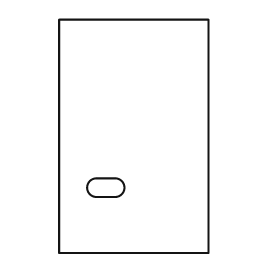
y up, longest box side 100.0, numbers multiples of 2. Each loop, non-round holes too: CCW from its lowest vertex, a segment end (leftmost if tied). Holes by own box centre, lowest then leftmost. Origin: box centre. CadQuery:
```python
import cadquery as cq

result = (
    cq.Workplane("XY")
    .moveTo(-32.0, -50.0)
    .lineTo(32.0, -50.0)
    .lineTo(32.0, 50.0)
    .lineTo(-32.0, 50.0)
    .close()
    .moveTo(-16.0, -26.0)
    .lineTo(-8.0, -26.0)
    .threePointArc((-4.0, -22.0), (-8.0, -18.0))
    .lineTo(-16.0, -18.0)
    .threePointArc((-20.0, -22.0), (-16.0, -26.0))
    .close()
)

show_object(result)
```